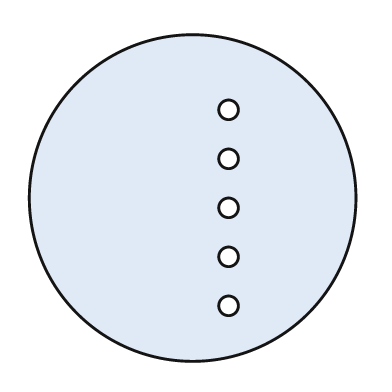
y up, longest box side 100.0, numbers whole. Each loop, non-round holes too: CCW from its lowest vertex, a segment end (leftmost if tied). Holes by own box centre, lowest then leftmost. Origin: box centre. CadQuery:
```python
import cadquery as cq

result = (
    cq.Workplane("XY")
    .moveTo(0.0, 0.0)
    .circle(50.0)
    .moveTo(11.0, -33.0)
    .circle(3.0)
    .moveTo(11.0, -18.0)
    .circle(3.0)
    .moveTo(11.0, -3.0)
    .circle(3.0)
    .moveTo(11.0, 12.0)
    .circle(3.0)
    .moveTo(11.0, 27.0)
    .circle(3.0)
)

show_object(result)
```